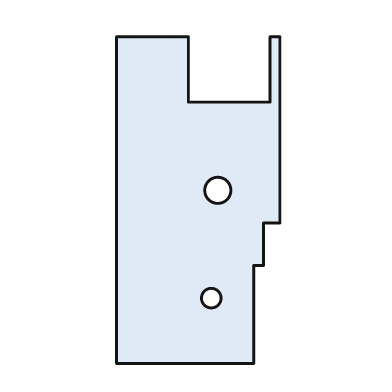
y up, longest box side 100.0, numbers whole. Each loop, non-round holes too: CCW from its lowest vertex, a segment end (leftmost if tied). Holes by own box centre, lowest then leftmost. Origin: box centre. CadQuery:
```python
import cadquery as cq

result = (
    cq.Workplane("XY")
    .moveTo(-25.0, -50.0)
    .lineTo(17.0, -50.0)
    .lineTo(17.0, -20.0)
    .lineTo(20.0, -20.0)
    .lineTo(20.0, -7.0)
    .lineTo(25.0, -7.0)
    .lineTo(25.0, 50.0)
    .lineTo(22.0, 50.0)
    .lineTo(22.0, 30.0)
    .lineTo(-3.0, 30.0)
    .lineTo(-3.0, 50.0)
    .lineTo(-25.0, 50.0)
    .close()
    .moveTo(4.0, -30.0)
    .circle(3.0)
    .moveTo(6.0, 3.0)
    .circle(4.0)
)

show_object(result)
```